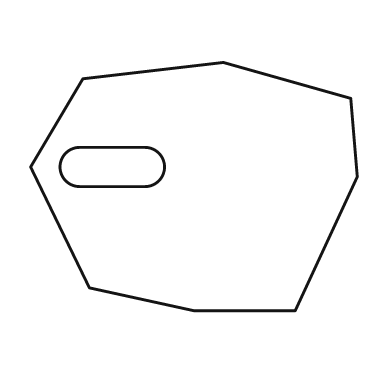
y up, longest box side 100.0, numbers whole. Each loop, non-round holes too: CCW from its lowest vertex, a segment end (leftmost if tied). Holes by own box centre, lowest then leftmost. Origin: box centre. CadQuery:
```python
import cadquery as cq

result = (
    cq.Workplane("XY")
    .moveTo(0.0, -38.0)
    .lineTo(31.0, -38.0)
    .lineTo(50.0, 3.0)
    .lineTo(48.0, 27.0)
    .lineTo(9.0, 38.0)
    .lineTo(-34.0, 33.0)
    .lineTo(-50.0, 6.0)
    .lineTo(-32.0, -31.0)
    .close()
    .moveTo(-35.0, 0.0)
    .lineTo(-15.0, 0.0)
    .threePointArc((-9.0, 6.0), (-15.0, 12.0))
    .lineTo(-35.0, 12.0)
    .threePointArc((-41.0, 6.0), (-35.0, 0.0))
    .close()
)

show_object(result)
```